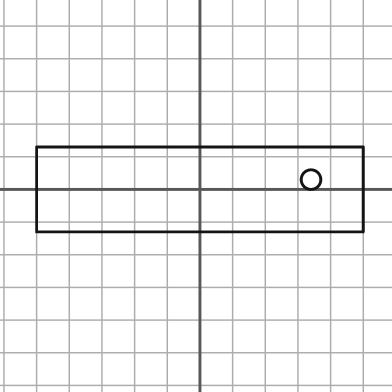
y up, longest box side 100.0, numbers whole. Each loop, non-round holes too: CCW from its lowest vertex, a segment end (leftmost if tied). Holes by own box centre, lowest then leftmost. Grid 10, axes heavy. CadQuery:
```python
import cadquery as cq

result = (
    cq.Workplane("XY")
    .moveTo(-50.0, -13.0)
    .lineTo(50.0, -13.0)
    .lineTo(50.0, 13.0)
    .lineTo(-50.0, 13.0)
    .close()
    .moveTo(34.0, 3.0)
    .circle(3.0)
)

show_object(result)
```